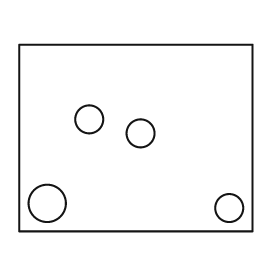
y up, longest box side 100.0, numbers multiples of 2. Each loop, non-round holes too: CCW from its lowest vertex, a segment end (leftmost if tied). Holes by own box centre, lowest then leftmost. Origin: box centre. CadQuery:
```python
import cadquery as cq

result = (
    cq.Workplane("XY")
    .moveTo(-50.0, -40.0)
    .lineTo(50.0, -40.0)
    .lineTo(50.0, 40.0)
    .lineTo(-50.0, 40.0)
    .close()
    .moveTo(40.0, -30.0)
    .circle(6.0)
    .moveTo(-38.0, -28.0)
    .circle(8.0)
    .moveTo(2.0, 2.0)
    .circle(6.0)
    .moveTo(-20.0, 8.0)
    .circle(6.0)
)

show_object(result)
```